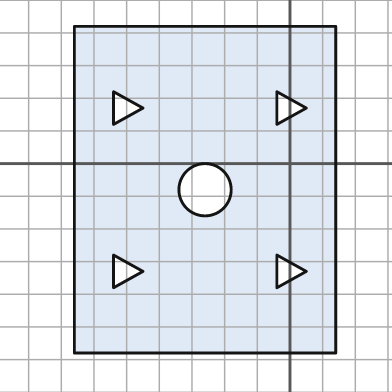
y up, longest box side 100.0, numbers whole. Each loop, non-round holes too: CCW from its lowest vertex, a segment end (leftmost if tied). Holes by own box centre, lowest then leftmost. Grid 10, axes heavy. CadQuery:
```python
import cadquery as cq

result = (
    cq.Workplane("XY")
    .moveTo(-66.0, -58.0)
    .lineTo(14.0, -58.0)
    .lineTo(14.0, 42.0)
    .lineTo(-66.0, 42.0)
    .close()
    .moveTo(-54.0, -38.0)
    .lineTo(-45.0, -33.0)
    .lineTo(-54.0, -28.0)
    .close()
    .moveTo(-4.0, -38.0)
    .lineTo(5.0, -33.0)
    .lineTo(-4.0, -28.0)
    .close()
    .moveTo(-26.0, -8.0)
    .circle(8.0)
    .moveTo(-54.0, 12.0)
    .lineTo(-45.0, 17.0)
    .lineTo(-54.0, 22.0)
    .close()
    .moveTo(-4.0, 12.0)
    .lineTo(5.0, 17.0)
    .lineTo(-4.0, 22.0)
    .close()
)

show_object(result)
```